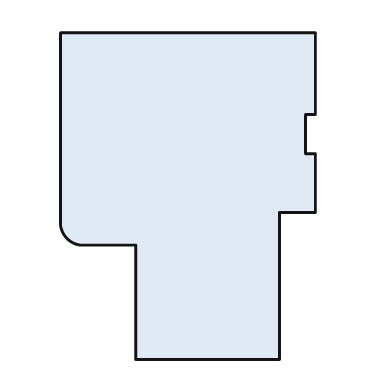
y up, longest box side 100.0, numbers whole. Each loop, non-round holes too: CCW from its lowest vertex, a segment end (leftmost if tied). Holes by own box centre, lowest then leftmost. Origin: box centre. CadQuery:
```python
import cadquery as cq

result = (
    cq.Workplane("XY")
    .moveTo(-16.0, -50.0)
    .lineTo(28.0, -50.0)
    .lineTo(28.0, -5.0)
    .lineTo(39.0, -5.0)
    .lineTo(39.0, 13.0)
    .lineTo(36.0, 13.0)
    .lineTo(36.0, 25.0)
    .lineTo(39.0, 25.0)
    .lineTo(39.0, 50.0)
    .lineTo(-39.0, 50.0)
    .lineTo(-39.0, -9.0)
    .threePointArc((-37.0, -13.0), (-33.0, -15.0))
    .lineTo(-16.0, -15.0)
    .close()
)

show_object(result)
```